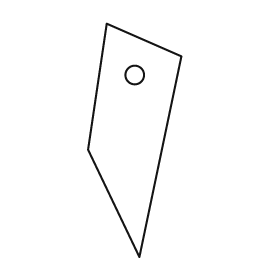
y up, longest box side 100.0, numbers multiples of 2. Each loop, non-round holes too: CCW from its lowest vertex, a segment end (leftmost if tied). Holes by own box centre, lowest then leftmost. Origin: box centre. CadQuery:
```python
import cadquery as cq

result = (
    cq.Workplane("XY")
    .moveTo(2.0, -50.0)
    .lineTo(20.0, 36.0)
    .lineTo(-12.0, 50.0)
    .lineTo(-20.0, -4.0)
    .close()
    .moveTo(0.0, 28.0)
    .circle(4.0)
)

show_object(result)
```